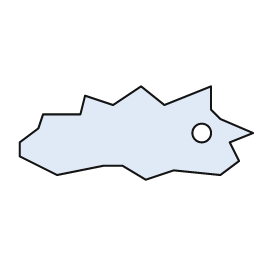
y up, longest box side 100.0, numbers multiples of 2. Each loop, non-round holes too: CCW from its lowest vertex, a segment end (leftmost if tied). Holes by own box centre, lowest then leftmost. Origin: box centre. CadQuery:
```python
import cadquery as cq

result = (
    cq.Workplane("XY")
    .moveTo(4.0, -20.0)
    .lineTo(16.0, -16.0)
    .lineTo(36.0, -18.0)
    .lineTo(44.0, -12.0)
    .lineTo(40.0, -4.0)
    .lineTo(50.0, 0.0)
    .lineTo(36.0, 6.0)
    .lineTo(32.0, 10.0)
    .lineTo(32.0, 20.0)
    .lineTo(12.0, 12.0)
    .lineTo(2.0, 20.0)
    .lineTo(-10.0, 12.0)
    .lineTo(-22.0, 16.0)
    .lineTo(-24.0, 8.0)
    .lineTo(-40.0, 8.0)
    .lineTo(-42.0, 2.0)
    .lineTo(-50.0, -4.0)
    .lineTo(-50.0, -10.0)
    .lineTo(-34.0, -18.0)
    .lineTo(-14.0, -14.0)
    .lineTo(-6.0, -14.0)
    .close()
    .moveTo(28.0, 0.0)
    .circle(4.0)
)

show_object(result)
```